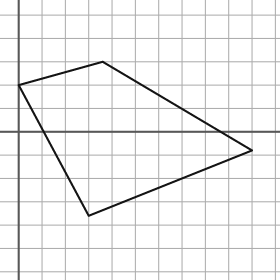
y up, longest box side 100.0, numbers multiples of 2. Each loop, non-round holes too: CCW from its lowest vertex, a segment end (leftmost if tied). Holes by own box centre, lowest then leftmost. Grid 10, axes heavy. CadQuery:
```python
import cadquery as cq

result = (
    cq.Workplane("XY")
    .moveTo(30.0, -36.0)
    .lineTo(100.0, -8.0)
    .lineTo(36.0, 30.0)
    .lineTo(0.0, 20.0)
    .close()
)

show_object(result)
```